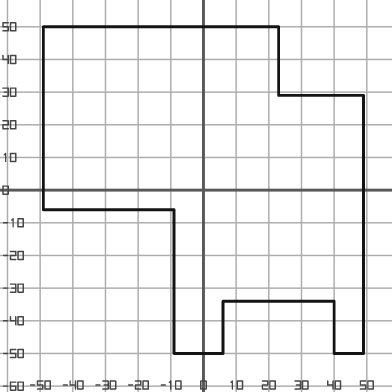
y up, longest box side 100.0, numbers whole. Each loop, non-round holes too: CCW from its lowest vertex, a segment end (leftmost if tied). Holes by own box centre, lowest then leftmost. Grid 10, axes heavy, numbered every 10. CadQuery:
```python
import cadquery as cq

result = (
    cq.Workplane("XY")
    .moveTo(-9.0, -50.0)
    .lineTo(6.0, -50.0)
    .lineTo(6.0, -34.0)
    .lineTo(40.0, -34.0)
    .lineTo(40.0, -50.0)
    .lineTo(49.0, -50.0)
    .lineTo(49.0, 29.0)
    .lineTo(23.0, 29.0)
    .lineTo(23.0, 50.0)
    .lineTo(-49.0, 50.0)
    .lineTo(-49.0, -6.0)
    .lineTo(-9.0, -6.0)
    .close()
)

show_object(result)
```